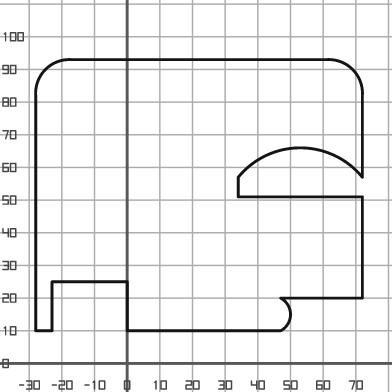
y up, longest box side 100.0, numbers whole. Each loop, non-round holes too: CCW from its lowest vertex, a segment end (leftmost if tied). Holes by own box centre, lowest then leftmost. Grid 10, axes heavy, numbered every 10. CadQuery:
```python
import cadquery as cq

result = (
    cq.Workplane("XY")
    .moveTo(-28.0, 10.0)
    .lineTo(-23.0, 10.0)
    .lineTo(-23.0, 25.0)
    .lineTo(0.0, 25.0)
    .lineTo(0.0, 10.0)
    .lineTo(47.0, 10.0)
    .threePointArc((50.0, 15.0), (47.0, 20.0))
    .lineTo(72.0, 20.0)
    .lineTo(72.0, 51.0)
    .lineTo(34.0, 51.0)
    .lineTo(34.0, 57.0)
    .threePointArc((53.0, 66.0), (72.0, 57.0))
    .lineTo(72.0, 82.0)
    .threePointArc((69.0, 90.0), (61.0, 93.0))
    .lineTo(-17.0, 93.0)
    .threePointArc((-25.0, 90.0), (-28.0, 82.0))
    .close()
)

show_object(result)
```